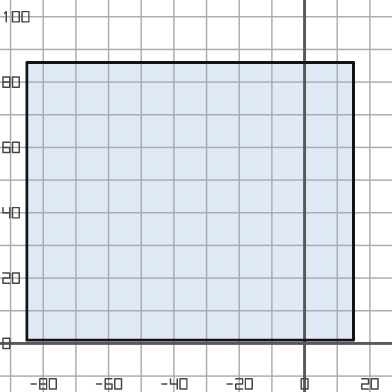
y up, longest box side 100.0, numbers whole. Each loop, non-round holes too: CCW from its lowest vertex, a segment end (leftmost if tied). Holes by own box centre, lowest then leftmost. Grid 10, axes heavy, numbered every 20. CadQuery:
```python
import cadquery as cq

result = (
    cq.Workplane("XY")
    .moveTo(-85.0, 1.0)
    .lineTo(15.0, 1.0)
    .lineTo(15.0, 86.0)
    .lineTo(-85.0, 86.0)
    .close()
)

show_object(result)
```